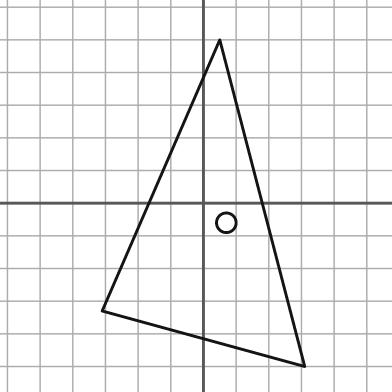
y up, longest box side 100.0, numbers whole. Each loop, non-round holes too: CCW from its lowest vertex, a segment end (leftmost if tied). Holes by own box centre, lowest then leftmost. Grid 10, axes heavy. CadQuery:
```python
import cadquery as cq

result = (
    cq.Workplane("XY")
    .moveTo(31.0, -50.0)
    .lineTo(5.0, 50.0)
    .lineTo(-31.0, -33.0)
    .close()
    .moveTo(7.0, -6.0)
    .circle(3.0)
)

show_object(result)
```